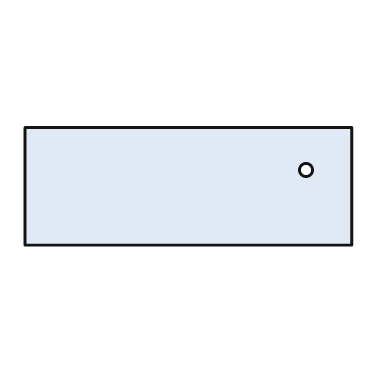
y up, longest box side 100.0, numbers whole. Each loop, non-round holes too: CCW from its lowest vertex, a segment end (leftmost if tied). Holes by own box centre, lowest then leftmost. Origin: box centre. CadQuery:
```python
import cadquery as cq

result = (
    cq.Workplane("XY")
    .moveTo(-50.0, -18.0)
    .lineTo(50.0, -18.0)
    .lineTo(50.0, 18.0)
    .lineTo(-50.0, 18.0)
    .close()
    .moveTo(36.0, 5.0)
    .circle(2.0)
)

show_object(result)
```